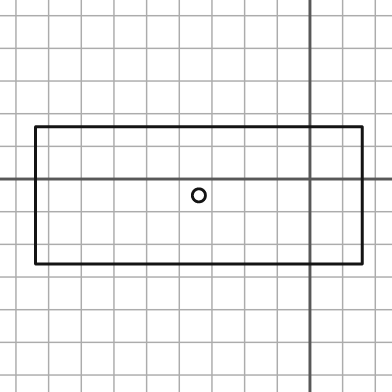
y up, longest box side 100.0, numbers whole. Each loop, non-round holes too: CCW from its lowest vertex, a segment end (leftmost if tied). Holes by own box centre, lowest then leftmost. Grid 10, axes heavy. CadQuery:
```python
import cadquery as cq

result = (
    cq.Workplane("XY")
    .moveTo(-84.0, -26.0)
    .lineTo(16.0, -26.0)
    .lineTo(16.0, 16.0)
    .lineTo(-84.0, 16.0)
    .close()
    .moveTo(-34.0, -5.0)
    .circle(2.0)
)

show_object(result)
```